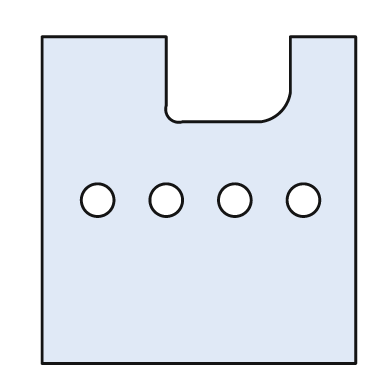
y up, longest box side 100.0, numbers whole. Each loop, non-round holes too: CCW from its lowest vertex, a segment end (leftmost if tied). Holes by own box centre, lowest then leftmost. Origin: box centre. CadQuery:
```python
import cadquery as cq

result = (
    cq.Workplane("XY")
    .moveTo(-48.0, -50.0)
    .lineTo(48.0, -50.0)
    .lineTo(48.0, 50.0)
    .lineTo(28.0, 50.0)
    .lineTo(28.0, 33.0)
    .threePointArc((25.0, 27.0), (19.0, 24.0))
    .lineTo(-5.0, 24.0)
    .threePointArc((-9.0, 25.0), (-10.0, 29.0))
    .lineTo(-10.0, 50.0)
    .lineTo(-48.0, 50.0)
    .close()
    .moveTo(-31.0, 0.0)
    .circle(5.0)
    .moveTo(-10.0, 0.0)
    .circle(5.0)
    .moveTo(11.0, 0.0)
    .circle(5.0)
    .moveTo(32.0, 0.0)
    .circle(5.0)
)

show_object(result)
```